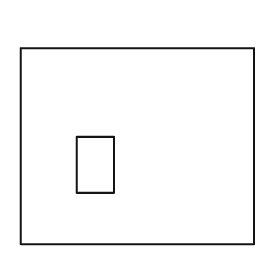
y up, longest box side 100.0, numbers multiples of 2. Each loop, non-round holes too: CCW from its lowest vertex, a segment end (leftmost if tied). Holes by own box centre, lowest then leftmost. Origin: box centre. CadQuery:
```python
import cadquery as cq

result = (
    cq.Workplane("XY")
    .moveTo(-50.0, -42.0)
    .lineTo(50.0, -42.0)
    .lineTo(50.0, 42.0)
    .lineTo(-50.0, 42.0)
    .close()
    .moveTo(-26.0, -20.0)
    .lineTo(-10.0, -20.0)
    .lineTo(-10.0, 4.0)
    .lineTo(-26.0, 4.0)
    .close()
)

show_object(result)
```